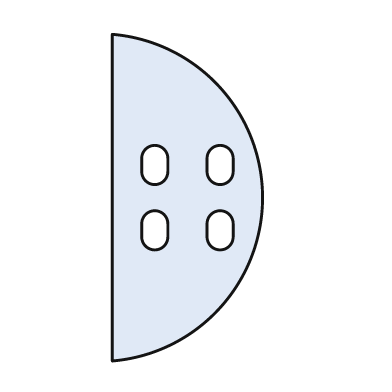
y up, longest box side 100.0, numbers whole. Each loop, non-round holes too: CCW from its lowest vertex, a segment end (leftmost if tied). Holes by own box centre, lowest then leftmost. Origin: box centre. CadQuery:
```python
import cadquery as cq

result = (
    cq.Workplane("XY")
    .moveTo(-23.0, -50.0)
    .threePointArc((23.0, 0.0), (-23.0, 50.0))
    .close()
    .moveTo(-14.0, -12.0)
    .threePointArc((-10.0, -16.0), (-6.0, -12.0))
    .lineTo(-6.0, -8.0)
    .threePointArc((-10.0, -4.0), (-14.0, -8.0))
    .close()
    .moveTo(6.0, -12.0)
    .threePointArc((10.0, -16.0), (14.0, -12.0))
    .lineTo(14.0, -8.0)
    .threePointArc((10.0, -4.0), (6.0, -8.0))
    .close()
    .moveTo(-14.0, 8.0)
    .threePointArc((-10.0, 4.0), (-6.0, 8.0))
    .lineTo(-6.0, 12.0)
    .threePointArc((-10.0, 16.0), (-14.0, 12.0))
    .close()
    .moveTo(6.0, 8.0)
    .threePointArc((10.0, 4.0), (14.0, 8.0))
    .lineTo(14.0, 12.0)
    .threePointArc((10.0, 16.0), (6.0, 12.0))
    .close()
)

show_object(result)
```